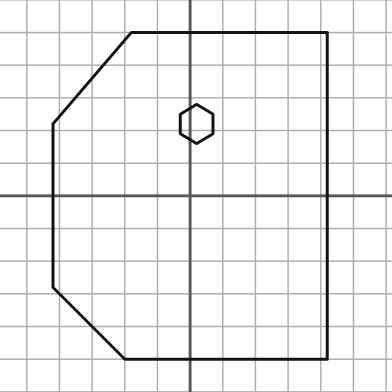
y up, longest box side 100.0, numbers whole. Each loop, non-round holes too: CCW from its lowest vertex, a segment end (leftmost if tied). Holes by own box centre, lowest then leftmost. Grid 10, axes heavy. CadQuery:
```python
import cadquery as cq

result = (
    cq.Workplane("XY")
    .moveTo(-20.0, -50.0)
    .lineTo(42.0, -50.0)
    .lineTo(42.0, 50.0)
    .lineTo(-18.0, 50.0)
    .lineTo(-42.0, 22.0)
    .lineTo(-42.0, -28.0)
    .close()
    .moveTo(2.0, 16.0)
    .lineTo(7.0, 19.0)
    .lineTo(7.0, 25.0)
    .lineTo(2.0, 28.0)
    .lineTo(-3.0, 25.0)
    .lineTo(-3.0, 19.0)
    .close()
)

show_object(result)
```